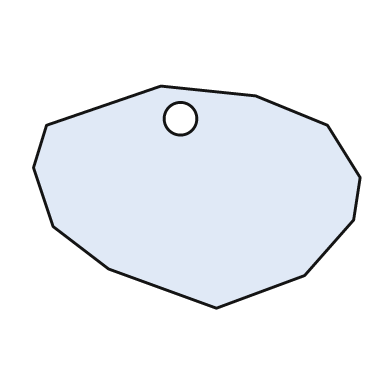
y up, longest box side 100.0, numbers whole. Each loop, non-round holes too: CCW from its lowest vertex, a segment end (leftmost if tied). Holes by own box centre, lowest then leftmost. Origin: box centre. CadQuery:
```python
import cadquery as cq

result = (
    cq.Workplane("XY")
    .moveTo(6.0, -34.0)
    .lineTo(33.0, -24.0)
    .lineTo(48.0, -7.0)
    .lineTo(50.0, 6.0)
    .lineTo(40.0, 22.0)
    .lineTo(18.0, 31.0)
    .lineTo(-11.0, 34.0)
    .lineTo(-46.0, 22.0)
    .lineTo(-50.0, 9.0)
    .lineTo(-44.0, -9.0)
    .lineTo(-27.0, -22.0)
    .close()
    .moveTo(-5.0, 24.0)
    .circle(5.0)
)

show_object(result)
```